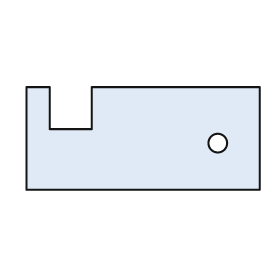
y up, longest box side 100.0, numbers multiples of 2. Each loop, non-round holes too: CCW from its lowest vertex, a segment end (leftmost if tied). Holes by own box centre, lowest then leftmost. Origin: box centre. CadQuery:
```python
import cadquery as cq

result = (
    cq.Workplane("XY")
    .moveTo(-50.0, -22.0)
    .lineTo(50.0, -22.0)
    .lineTo(50.0, 22.0)
    .lineTo(-22.0, 22.0)
    .lineTo(-22.0, 4.0)
    .lineTo(-40.0, 4.0)
    .lineTo(-40.0, 22.0)
    .lineTo(-50.0, 22.0)
    .close()
    .moveTo(32.0, -2.0)
    .circle(4.0)
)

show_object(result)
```